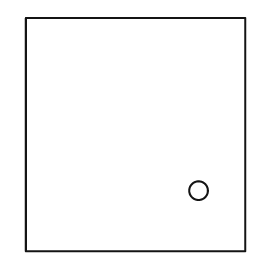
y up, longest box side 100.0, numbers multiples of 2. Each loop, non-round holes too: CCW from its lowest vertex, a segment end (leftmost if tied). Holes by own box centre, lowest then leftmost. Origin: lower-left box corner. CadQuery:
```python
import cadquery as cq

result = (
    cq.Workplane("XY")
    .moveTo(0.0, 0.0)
    .lineTo(94.0, 0.0)
    .lineTo(94.0, 100.0)
    .lineTo(0.0, 100.0)
    .close()
    .moveTo(74.0, 26.0)
    .circle(4.0)
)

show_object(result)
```